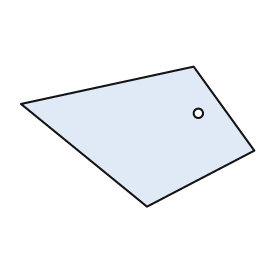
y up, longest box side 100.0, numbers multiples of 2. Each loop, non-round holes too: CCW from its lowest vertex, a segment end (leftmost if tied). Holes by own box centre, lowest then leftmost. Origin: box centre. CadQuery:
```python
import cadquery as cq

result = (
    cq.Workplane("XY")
    .moveTo(4.0, -30.0)
    .lineTo(50.0, -6.0)
    .lineTo(24.0, 30.0)
    .lineTo(-50.0, 14.0)
    .close()
    .moveTo(26.0, 10.0)
    .circle(2.0)
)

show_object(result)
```